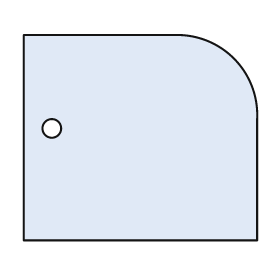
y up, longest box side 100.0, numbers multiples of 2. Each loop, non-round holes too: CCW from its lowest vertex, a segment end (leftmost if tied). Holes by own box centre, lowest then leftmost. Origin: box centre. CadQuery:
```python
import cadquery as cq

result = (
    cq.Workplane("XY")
    .moveTo(-50.0, -44.0)
    .lineTo(50.0, -44.0)
    .lineTo(50.0, 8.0)
    .threePointArc((40.0, 34.0), (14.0, 44.0))
    .lineTo(-50.0, 44.0)
    .close()
    .moveTo(-38.0, 4.0)
    .circle(4.0)
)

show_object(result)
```